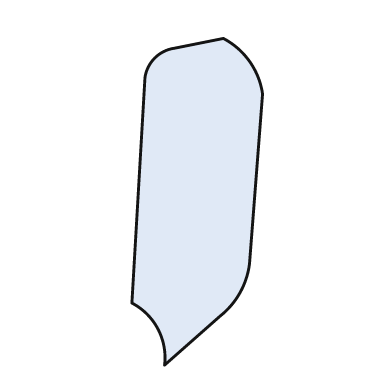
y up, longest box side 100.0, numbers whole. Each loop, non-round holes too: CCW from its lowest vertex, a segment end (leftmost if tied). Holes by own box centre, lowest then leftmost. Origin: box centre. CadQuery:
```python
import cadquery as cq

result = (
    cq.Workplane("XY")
    .moveTo(-10.0, -50.0)
    .lineTo(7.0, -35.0)
    .threePointArc((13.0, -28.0), (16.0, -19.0))
    .lineTo(20.0, 33.0)
    .threePointArc((16.0, 43.0), (8.0, 50.0))
    .lineTo(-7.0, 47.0)
    .threePointArc((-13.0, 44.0), (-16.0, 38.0))
    .lineTo(-20.0, -31.0)
    .threePointArc((-12.0, -39.0), (-10.0, -50.0))
    .close()
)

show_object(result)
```